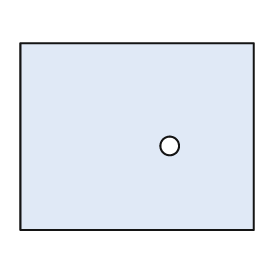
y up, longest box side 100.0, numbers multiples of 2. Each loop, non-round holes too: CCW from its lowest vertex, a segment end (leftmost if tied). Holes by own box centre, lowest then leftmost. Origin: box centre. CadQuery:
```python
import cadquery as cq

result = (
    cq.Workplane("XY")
    .moveTo(-50.0, -40.0)
    .lineTo(50.0, -40.0)
    .lineTo(50.0, 40.0)
    .lineTo(-50.0, 40.0)
    .close()
    .moveTo(14.0, -4.0)
    .circle(4.0)
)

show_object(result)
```